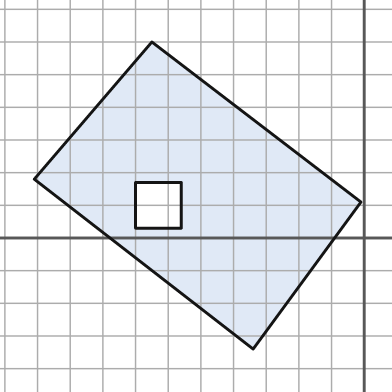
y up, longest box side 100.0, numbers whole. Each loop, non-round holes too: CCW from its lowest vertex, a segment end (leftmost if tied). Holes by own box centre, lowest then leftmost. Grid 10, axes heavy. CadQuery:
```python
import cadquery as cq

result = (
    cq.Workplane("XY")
    .moveTo(-34.0, -34.0)
    .lineTo(-1.0, 11.0)
    .lineTo(-65.0, 60.0)
    .lineTo(-101.0, 18.0)
    .close()
    .moveTo(-70.0, 3.0)
    .lineTo(-56.0, 3.0)
    .lineTo(-56.0, 17.0)
    .lineTo(-70.0, 17.0)
    .close()
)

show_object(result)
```